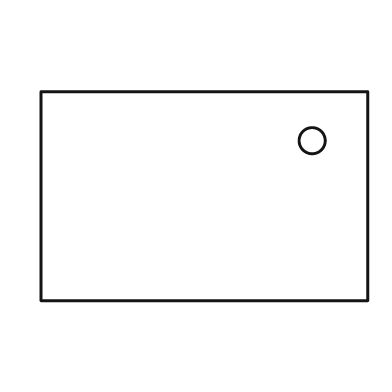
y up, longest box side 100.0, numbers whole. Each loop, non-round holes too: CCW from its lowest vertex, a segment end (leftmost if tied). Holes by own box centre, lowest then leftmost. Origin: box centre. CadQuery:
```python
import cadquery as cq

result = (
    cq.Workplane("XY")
    .moveTo(-50.0, -32.0)
    .lineTo(50.0, -32.0)
    .lineTo(50.0, 32.0)
    .lineTo(-50.0, 32.0)
    .close()
    .moveTo(33.0, 17.0)
    .circle(4.0)
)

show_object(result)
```